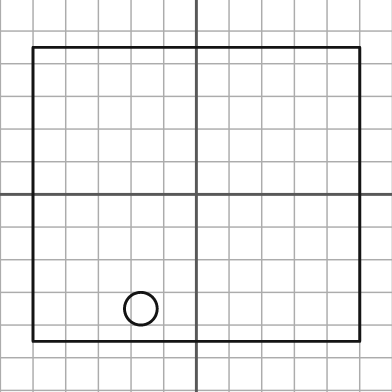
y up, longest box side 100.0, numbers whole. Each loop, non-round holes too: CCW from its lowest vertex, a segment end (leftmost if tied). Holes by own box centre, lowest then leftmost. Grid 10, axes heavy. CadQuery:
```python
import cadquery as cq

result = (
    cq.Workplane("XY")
    .moveTo(-50.0, -45.0)
    .lineTo(50.0, -45.0)
    .lineTo(50.0, 45.0)
    .lineTo(-50.0, 45.0)
    .close()
    .moveTo(-17.0, -35.0)
    .circle(5.0)
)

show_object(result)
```